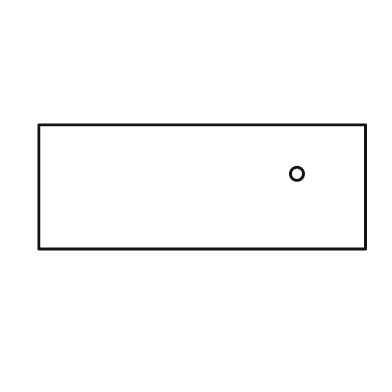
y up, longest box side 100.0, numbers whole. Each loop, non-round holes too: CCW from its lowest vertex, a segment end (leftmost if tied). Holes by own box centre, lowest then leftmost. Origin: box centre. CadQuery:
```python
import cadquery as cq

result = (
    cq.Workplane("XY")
    .moveTo(-50.0, -19.0)
    .lineTo(50.0, -19.0)
    .lineTo(50.0, 19.0)
    .lineTo(-50.0, 19.0)
    .close()
    .moveTo(29.0, 4.0)
    .circle(2.0)
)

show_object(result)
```